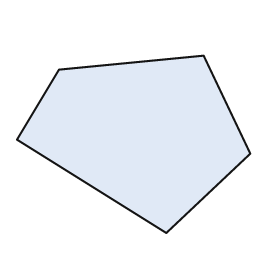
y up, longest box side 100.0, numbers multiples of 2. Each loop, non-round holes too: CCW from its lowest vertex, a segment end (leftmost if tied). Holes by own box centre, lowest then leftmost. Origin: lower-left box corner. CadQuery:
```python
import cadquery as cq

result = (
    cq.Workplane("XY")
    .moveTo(64.0, 0.0)
    .lineTo(100.0, 34.0)
    .lineTo(80.0, 76.0)
    .lineTo(18.0, 70.0)
    .lineTo(0.0, 40.0)
    .close()
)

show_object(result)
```